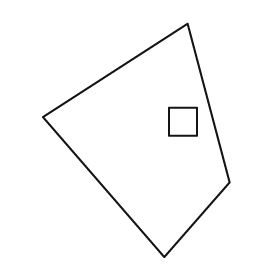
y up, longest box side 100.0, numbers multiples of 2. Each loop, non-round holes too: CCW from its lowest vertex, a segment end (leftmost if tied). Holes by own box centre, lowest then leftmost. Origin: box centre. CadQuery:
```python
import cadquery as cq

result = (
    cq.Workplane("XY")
    .moveTo(12.0, -50.0)
    .lineTo(40.0, -18.0)
    .lineTo(22.0, 50.0)
    .lineTo(-40.0, 10.0)
    .close()
    .moveTo(14.0, 2.0)
    .lineTo(26.0, 2.0)
    .lineTo(26.0, 14.0)
    .lineTo(14.0, 14.0)
    .close()
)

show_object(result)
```